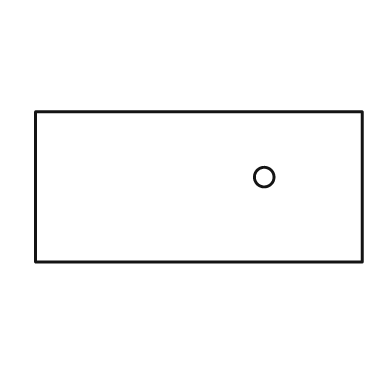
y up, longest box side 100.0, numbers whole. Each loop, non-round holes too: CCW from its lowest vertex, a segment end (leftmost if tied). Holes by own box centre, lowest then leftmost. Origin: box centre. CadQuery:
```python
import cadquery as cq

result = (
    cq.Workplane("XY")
    .moveTo(-50.0, -23.0)
    .lineTo(50.0, -23.0)
    .lineTo(50.0, 23.0)
    .lineTo(-50.0, 23.0)
    .close()
    .moveTo(20.0, 3.0)
    .circle(3.0)
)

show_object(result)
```